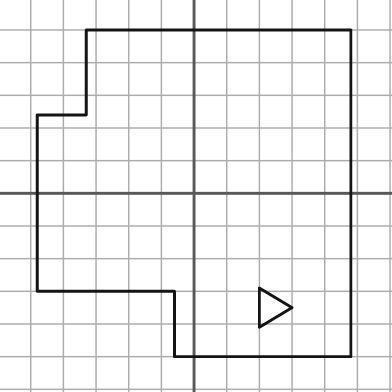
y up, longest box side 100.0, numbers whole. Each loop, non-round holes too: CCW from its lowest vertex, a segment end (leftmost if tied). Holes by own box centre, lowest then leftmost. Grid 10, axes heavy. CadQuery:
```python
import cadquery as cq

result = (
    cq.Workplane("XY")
    .moveTo(-6.0, -50.0)
    .lineTo(48.0, -50.0)
    .lineTo(48.0, 50.0)
    .lineTo(-33.0, 50.0)
    .lineTo(-33.0, 24.0)
    .lineTo(-48.0, 24.0)
    .lineTo(-48.0, -30.0)
    .lineTo(-6.0, -30.0)
    .close()
    .moveTo(20.0, -41.0)
    .lineTo(30.0, -35.0)
    .lineTo(20.0, -29.0)
    .close()
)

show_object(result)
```